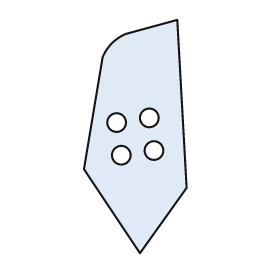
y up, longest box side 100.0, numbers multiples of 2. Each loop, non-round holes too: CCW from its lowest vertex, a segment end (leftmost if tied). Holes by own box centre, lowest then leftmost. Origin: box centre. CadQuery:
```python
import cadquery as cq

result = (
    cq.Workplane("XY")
    .moveTo(2.0, -50.0)
    .lineTo(22.0, -22.0)
    .lineTo(18.0, 50.0)
    .lineTo(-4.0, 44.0)
    .threePointArc((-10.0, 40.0), (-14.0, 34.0))
    .lineTo(-22.0, -14.0)
    .close()
    .moveTo(-6.0, -8.0)
    .circle(4.0)
    .moveTo(8.0, -6.0)
    .circle(4.0)
    .moveTo(-8.0, 6.0)
    .circle(4.0)
    .moveTo(6.0, 8.0)
    .circle(4.0)
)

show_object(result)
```